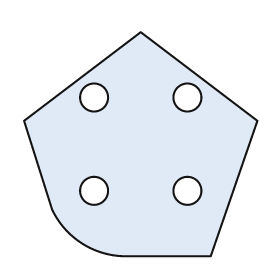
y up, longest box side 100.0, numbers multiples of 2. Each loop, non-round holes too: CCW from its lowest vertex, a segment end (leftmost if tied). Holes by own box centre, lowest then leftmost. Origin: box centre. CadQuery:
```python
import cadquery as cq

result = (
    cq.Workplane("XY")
    .moveTo(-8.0, -48.0)
    .lineTo(30.0, -48.0)
    .lineTo(50.0, 10.0)
    .lineTo(0.0, 48.0)
    .lineTo(-50.0, 10.0)
    .lineTo(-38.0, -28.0)
    .threePointArc((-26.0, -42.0), (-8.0, -48.0))
    .close()
    .moveTo(-20.0, -20.0)
    .circle(6.0)
    .moveTo(20.0, -20.0)
    .circle(6.0)
    .moveTo(-20.0, 20.0)
    .circle(6.0)
    .moveTo(20.0, 20.0)
    .circle(6.0)
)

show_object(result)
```